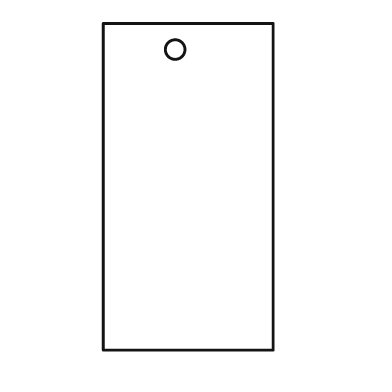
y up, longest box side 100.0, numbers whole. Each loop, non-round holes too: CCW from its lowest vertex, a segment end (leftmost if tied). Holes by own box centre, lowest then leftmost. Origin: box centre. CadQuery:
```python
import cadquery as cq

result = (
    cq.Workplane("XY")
    .moveTo(-26.0, -50.0)
    .lineTo(26.0, -50.0)
    .lineTo(26.0, 50.0)
    .lineTo(-26.0, 50.0)
    .close()
    .moveTo(-4.0, 42.0)
    .circle(3.0)
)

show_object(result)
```